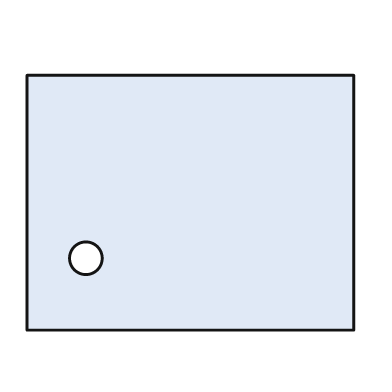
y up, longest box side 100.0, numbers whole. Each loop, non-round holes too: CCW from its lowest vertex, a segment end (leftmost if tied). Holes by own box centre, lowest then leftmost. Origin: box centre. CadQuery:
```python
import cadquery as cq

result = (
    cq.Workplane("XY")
    .moveTo(-50.0, -39.0)
    .lineTo(50.0, -39.0)
    .lineTo(50.0, 39.0)
    .lineTo(-50.0, 39.0)
    .close()
    .moveTo(-32.0, -17.0)
    .circle(5.0)
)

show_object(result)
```